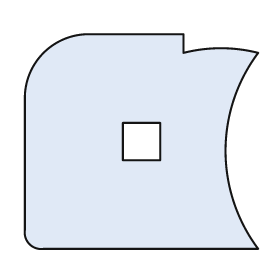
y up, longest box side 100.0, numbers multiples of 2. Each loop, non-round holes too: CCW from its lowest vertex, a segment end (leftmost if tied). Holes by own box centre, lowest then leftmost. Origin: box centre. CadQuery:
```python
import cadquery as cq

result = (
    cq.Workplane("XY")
    .moveTo(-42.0, -46.0)
    .lineTo(50.0, -46.0)
    .threePointArc((36.0, -4.0), (50.0, 38.0))
    .threePointArc((34.0, 40.0), (18.0, 38.0))
    .lineTo(18.0, 46.0)
    .lineTo(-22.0, 46.0)
    .threePointArc((-42.0, 38.0), (-50.0, 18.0))
    .lineTo(-50.0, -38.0)
    .threePointArc((-48.0, -44.0), (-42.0, -46.0))
    .close()
    .moveTo(-8.0, -8.0)
    .lineTo(8.0, -8.0)
    .lineTo(8.0, 8.0)
    .lineTo(-8.0, 8.0)
    .close()
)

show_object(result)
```